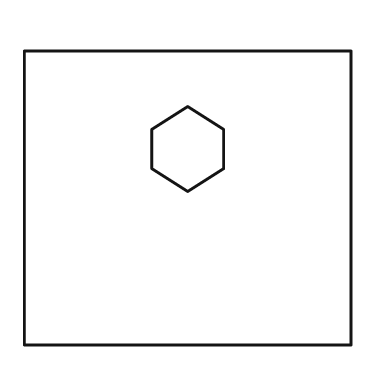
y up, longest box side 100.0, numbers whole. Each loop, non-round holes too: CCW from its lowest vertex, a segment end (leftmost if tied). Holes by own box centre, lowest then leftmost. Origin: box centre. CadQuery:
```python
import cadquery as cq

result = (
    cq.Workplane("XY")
    .moveTo(-50.0, -45.0)
    .lineTo(50.0, -45.0)
    .lineTo(50.0, 45.0)
    .lineTo(-50.0, 45.0)
    .close()
    .moveTo(0.0, 2.0)
    .lineTo(11.0, 9.0)
    .lineTo(11.0, 21.0)
    .lineTo(0.0, 28.0)
    .lineTo(-11.0, 21.0)
    .lineTo(-11.0, 9.0)
    .close()
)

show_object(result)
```